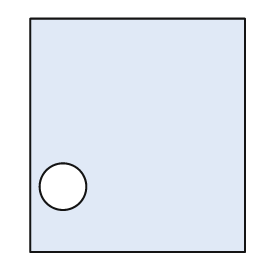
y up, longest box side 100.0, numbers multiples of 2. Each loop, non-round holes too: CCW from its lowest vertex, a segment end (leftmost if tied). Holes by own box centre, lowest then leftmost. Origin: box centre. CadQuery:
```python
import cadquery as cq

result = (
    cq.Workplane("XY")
    .moveTo(-46.0, -50.0)
    .lineTo(46.0, -50.0)
    .lineTo(46.0, 50.0)
    .lineTo(-46.0, 50.0)
    .close()
    .moveTo(-32.0, -22.0)
    .circle(10.0)
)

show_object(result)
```